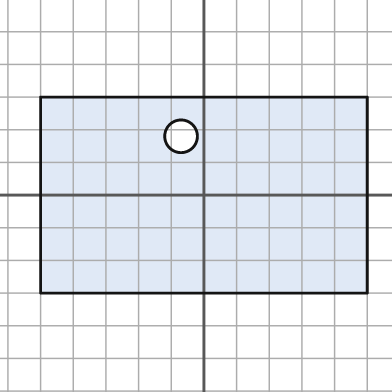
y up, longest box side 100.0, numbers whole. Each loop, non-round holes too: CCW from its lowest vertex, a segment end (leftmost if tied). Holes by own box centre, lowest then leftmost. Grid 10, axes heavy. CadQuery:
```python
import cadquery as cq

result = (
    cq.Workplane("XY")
    .moveTo(-50.0, -30.0)
    .lineTo(50.0, -30.0)
    .lineTo(50.0, 30.0)
    .lineTo(-50.0, 30.0)
    .close()
    .moveTo(-7.0, 18.0)
    .circle(5.0)
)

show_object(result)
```